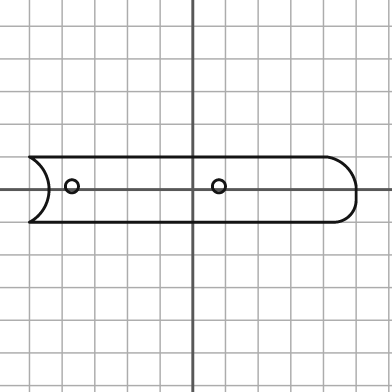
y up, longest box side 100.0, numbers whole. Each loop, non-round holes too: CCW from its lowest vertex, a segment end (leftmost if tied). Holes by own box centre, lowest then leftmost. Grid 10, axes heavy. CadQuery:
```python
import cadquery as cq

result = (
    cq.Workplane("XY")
    .moveTo(-50.0, -10.0)
    .lineTo(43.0, -10.0)
    .threePointArc((48.0, -8.0), (50.0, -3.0))
    .lineTo(50.0, 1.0)
    .threePointArc((47.0, 7.0), (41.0, 10.0))
    .lineTo(-50.0, 10.0)
    .threePointArc((-44.0, 0.0), (-50.0, -10.0))
    .close()
    .moveTo(-37.0, 1.0)
    .circle(2.0)
    .moveTo(8.0, 1.0)
    .circle(2.0)
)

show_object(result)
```